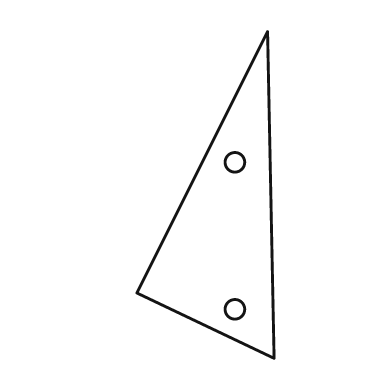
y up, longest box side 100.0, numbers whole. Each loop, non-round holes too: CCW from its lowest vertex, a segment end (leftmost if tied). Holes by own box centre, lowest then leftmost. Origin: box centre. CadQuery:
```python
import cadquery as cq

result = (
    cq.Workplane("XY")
    .moveTo(21.0, -50.0)
    .lineTo(19.0, 50.0)
    .lineTo(-21.0, -30.0)
    .close()
    .moveTo(9.0, -35.0)
    .circle(3.0)
    .moveTo(9.0, 10.0)
    .circle(3.0)
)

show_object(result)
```